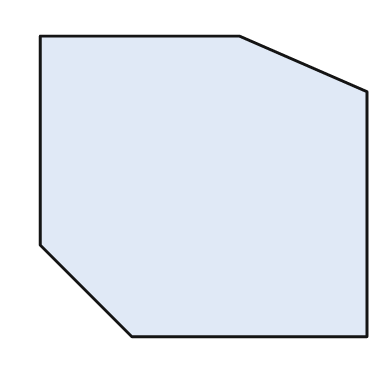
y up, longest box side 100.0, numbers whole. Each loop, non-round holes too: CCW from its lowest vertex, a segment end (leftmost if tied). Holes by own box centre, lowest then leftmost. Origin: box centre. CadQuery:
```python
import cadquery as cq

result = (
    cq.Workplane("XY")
    .moveTo(-22.0, -46.0)
    .lineTo(50.0, -46.0)
    .lineTo(50.0, 29.0)
    .lineTo(11.0, 46.0)
    .lineTo(-50.0, 46.0)
    .lineTo(-50.0, -18.0)
    .close()
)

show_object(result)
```